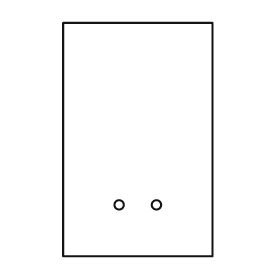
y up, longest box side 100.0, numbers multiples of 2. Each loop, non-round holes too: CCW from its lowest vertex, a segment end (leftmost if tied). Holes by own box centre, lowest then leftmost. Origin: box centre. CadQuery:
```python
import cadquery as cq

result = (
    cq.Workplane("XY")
    .moveTo(-32.0, -50.0)
    .lineTo(32.0, -50.0)
    .lineTo(32.0, 50.0)
    .lineTo(-32.0, 50.0)
    .close()
    .moveTo(-8.0, -28.0)
    .circle(2.0)
    .moveTo(8.0, -28.0)
    .circle(2.0)
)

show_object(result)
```